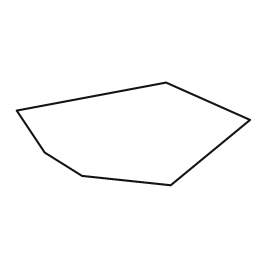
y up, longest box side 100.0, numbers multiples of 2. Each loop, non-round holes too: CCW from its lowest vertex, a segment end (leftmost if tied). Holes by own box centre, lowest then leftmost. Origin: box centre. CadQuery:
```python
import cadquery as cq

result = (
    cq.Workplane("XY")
    .moveTo(16.0, -22.0)
    .lineTo(50.0, 6.0)
    .lineTo(14.0, 22.0)
    .lineTo(-50.0, 10.0)
    .lineTo(-38.0, -8.0)
    .lineTo(-22.0, -18.0)
    .close()
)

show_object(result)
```